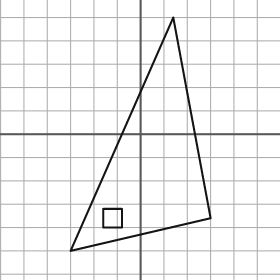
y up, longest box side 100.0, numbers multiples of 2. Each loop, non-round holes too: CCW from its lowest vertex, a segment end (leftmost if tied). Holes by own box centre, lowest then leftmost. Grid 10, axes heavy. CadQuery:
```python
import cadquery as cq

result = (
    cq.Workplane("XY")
    .moveTo(-30.0, -50.0)
    .lineTo(30.0, -36.0)
    .lineTo(14.0, 50.0)
    .close()
    .moveTo(-16.0, -40.0)
    .lineTo(-8.0, -40.0)
    .lineTo(-8.0, -32.0)
    .lineTo(-16.0, -32.0)
    .close()
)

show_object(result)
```